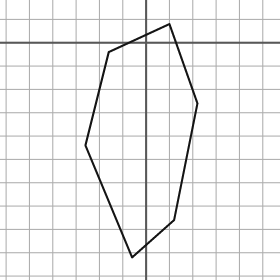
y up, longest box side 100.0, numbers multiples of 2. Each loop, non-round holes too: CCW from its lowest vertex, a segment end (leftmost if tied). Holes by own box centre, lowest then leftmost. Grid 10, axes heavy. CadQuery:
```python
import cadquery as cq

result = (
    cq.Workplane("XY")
    .moveTo(-6.0, -92.0)
    .lineTo(12.0, -76.0)
    .lineTo(22.0, -26.0)
    .lineTo(10.0, 8.0)
    .lineTo(-16.0, -4.0)
    .lineTo(-26.0, -44.0)
    .close()
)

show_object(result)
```